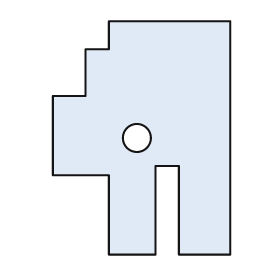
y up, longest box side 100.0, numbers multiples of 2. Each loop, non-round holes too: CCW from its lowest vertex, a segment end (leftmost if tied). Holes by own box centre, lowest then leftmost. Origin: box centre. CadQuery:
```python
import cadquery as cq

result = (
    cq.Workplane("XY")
    .moveTo(-14.0, -50.0)
    .lineTo(6.0, -50.0)
    .lineTo(6.0, -12.0)
    .lineTo(16.0, -12.0)
    .lineTo(16.0, -50.0)
    .lineTo(38.0, -50.0)
    .lineTo(38.0, 50.0)
    .lineTo(-14.0, 50.0)
    .lineTo(-14.0, 38.0)
    .lineTo(-24.0, 38.0)
    .lineTo(-24.0, 18.0)
    .lineTo(-38.0, 18.0)
    .lineTo(-38.0, -16.0)
    .lineTo(-14.0, -16.0)
    .close()
    .moveTo(-2.0, 0.0)
    .circle(6.0)
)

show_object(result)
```